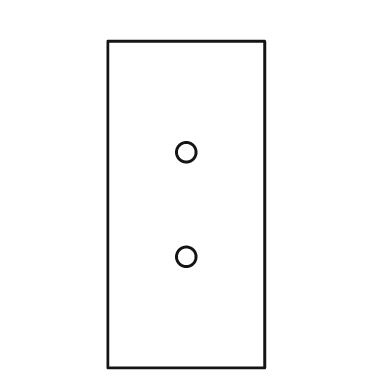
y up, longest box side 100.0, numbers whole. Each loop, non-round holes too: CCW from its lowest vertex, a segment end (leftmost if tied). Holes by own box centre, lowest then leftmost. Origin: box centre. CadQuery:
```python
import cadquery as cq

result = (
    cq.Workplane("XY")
    .moveTo(-24.0, -50.0)
    .lineTo(24.0, -50.0)
    .lineTo(24.0, 50.0)
    .lineTo(-24.0, 50.0)
    .close()
    .moveTo(0.0, -16.0)
    .circle(3.0)
    .moveTo(0.0, 16.0)
    .circle(3.0)
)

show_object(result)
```